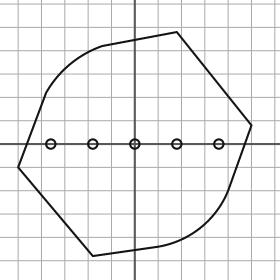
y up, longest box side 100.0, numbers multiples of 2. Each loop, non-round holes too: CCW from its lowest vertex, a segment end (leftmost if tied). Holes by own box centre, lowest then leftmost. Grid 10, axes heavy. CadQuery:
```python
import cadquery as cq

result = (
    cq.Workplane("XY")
    .moveTo(-18.0, -48.0)
    .lineTo(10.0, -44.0)
    .threePointArc((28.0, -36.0), (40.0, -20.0))
    .lineTo(50.0, 8.0)
    .lineTo(18.0, 48.0)
    .lineTo(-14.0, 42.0)
    .threePointArc((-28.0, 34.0), (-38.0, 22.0))
    .lineTo(-50.0, -10.0)
    .close()
    .moveTo(-36.0, 0.0)
    .circle(2.0)
    .moveTo(-18.0, 0.0)
    .circle(2.0)
    .moveTo(0.0, 0.0)
    .circle(2.0)
    .moveTo(18.0, 0.0)
    .circle(2.0)
    .moveTo(36.0, 0.0)
    .circle(2.0)
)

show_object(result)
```